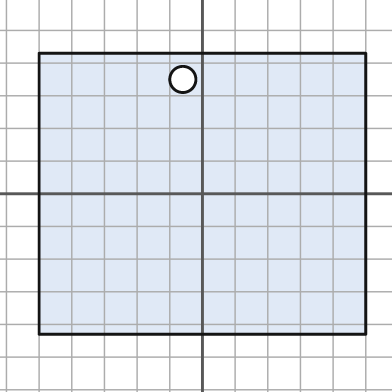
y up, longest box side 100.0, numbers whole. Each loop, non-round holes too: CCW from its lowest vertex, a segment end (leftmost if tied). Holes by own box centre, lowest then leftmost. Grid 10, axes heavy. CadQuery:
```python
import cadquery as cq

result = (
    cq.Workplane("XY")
    .moveTo(-50.0, -43.0)
    .lineTo(50.0, -43.0)
    .lineTo(50.0, 43.0)
    .lineTo(-50.0, 43.0)
    .close()
    .moveTo(-6.0, 35.0)
    .circle(4.0)
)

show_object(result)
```